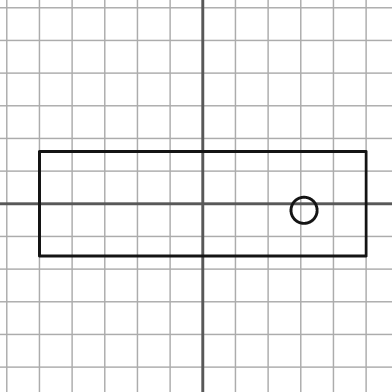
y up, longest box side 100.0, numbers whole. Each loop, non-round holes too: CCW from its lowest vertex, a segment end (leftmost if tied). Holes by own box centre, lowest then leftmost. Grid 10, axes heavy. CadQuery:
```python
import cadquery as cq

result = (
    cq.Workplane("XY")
    .moveTo(-50.0, -16.0)
    .lineTo(50.0, -16.0)
    .lineTo(50.0, 16.0)
    .lineTo(-50.0, 16.0)
    .close()
    .moveTo(31.0, -2.0)
    .circle(4.0)
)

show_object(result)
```